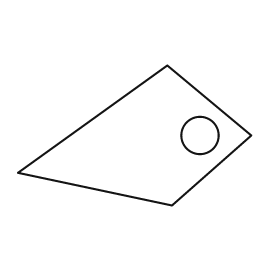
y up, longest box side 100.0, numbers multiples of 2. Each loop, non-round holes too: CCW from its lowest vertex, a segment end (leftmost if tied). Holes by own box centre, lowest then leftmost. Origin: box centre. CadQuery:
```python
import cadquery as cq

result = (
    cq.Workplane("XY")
    .moveTo(16.0, -30.0)
    .lineTo(50.0, 0.0)
    .lineTo(14.0, 30.0)
    .lineTo(-50.0, -16.0)
    .close()
    .moveTo(28.0, 0.0)
    .circle(8.0)
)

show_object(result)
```